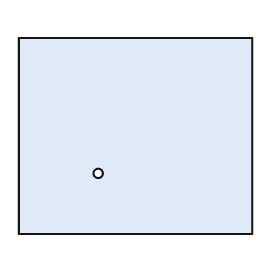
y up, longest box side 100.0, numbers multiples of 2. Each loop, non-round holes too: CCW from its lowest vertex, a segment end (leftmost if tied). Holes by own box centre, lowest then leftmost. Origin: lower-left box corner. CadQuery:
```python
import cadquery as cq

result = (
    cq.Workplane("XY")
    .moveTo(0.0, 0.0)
    .lineTo(100.0, 0.0)
    .lineTo(100.0, 84.0)
    .lineTo(0.0, 84.0)
    .close()
    .moveTo(34.0, 26.0)
    .circle(2.0)
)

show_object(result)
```